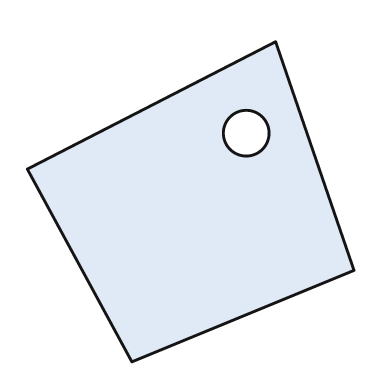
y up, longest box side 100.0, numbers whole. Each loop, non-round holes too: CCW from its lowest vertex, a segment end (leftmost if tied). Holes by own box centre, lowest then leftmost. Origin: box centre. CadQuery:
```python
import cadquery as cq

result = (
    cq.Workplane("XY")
    .moveTo(-18.0, -49.0)
    .lineTo(50.0, -21.0)
    .lineTo(26.0, 49.0)
    .lineTo(-50.0, 10.0)
    .close()
    .moveTo(17.0, 21.0)
    .circle(7.0)
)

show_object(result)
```